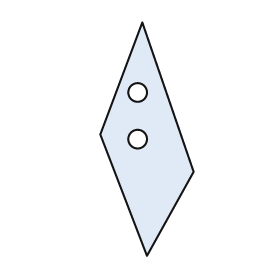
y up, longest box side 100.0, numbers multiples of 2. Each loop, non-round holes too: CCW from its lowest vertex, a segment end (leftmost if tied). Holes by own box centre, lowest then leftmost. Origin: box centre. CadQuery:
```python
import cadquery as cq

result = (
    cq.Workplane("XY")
    .moveTo(0.0, -50.0)
    .lineTo(20.0, -14.0)
    .lineTo(-2.0, 50.0)
    .lineTo(-20.0, 2.0)
    .close()
    .moveTo(-4.0, 0.0)
    .circle(4.0)
    .moveTo(-4.0, 20.0)
    .circle(4.0)
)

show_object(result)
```